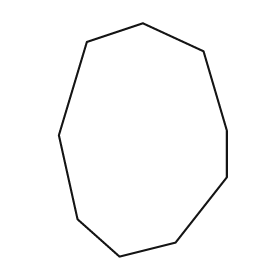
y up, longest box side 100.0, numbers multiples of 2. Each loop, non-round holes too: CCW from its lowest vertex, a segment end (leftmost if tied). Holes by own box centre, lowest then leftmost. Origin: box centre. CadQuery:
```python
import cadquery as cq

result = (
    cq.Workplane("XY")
    .moveTo(-10.0, -50.0)
    .lineTo(14.0, -44.0)
    .lineTo(36.0, -16.0)
    .lineTo(36.0, 4.0)
    .lineTo(26.0, 38.0)
    .lineTo(0.0, 50.0)
    .lineTo(-24.0, 42.0)
    .lineTo(-36.0, 2.0)
    .lineTo(-28.0, -34.0)
    .close()
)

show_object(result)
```